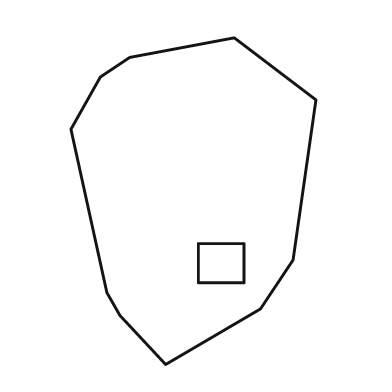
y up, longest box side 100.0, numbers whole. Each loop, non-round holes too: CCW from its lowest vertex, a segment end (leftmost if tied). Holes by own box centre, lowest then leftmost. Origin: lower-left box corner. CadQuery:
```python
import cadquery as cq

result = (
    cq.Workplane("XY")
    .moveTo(29.0, 0.0)
    .lineTo(58.0, 17.0)
    .lineTo(68.0, 32.0)
    .lineTo(75.0, 81.0)
    .lineTo(50.0, 100.0)
    .lineTo(18.0, 94.0)
    .lineTo(9.0, 88.0)
    .lineTo(0.0, 72.0)
    .lineTo(11.0, 22.0)
    .lineTo(15.0, 15.0)
    .close()
    .moveTo(39.0, 25.0)
    .lineTo(53.0, 25.0)
    .lineTo(53.0, 37.0)
    .lineTo(39.0, 37.0)
    .close()
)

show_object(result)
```